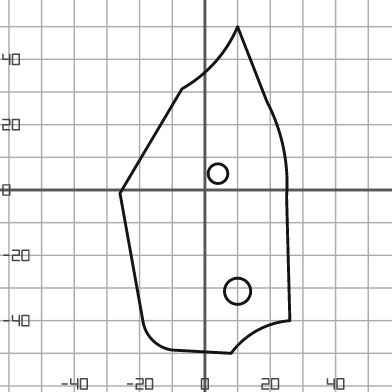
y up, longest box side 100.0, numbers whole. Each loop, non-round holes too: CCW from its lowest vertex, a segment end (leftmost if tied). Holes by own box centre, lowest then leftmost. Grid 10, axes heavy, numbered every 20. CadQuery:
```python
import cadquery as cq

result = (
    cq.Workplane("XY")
    .moveTo(8.0, -50.0)
    .threePointArc((16.0, -43.0), (26.0, -40.0))
    .lineTo(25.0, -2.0)
    .threePointArc((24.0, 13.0), (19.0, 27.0))
    .lineTo(10.0, 50.0)
    .threePointArc((3.0, 39.0), (-7.0, 31.0))
    .lineTo(-26.0, -1.0)
    .lineTo(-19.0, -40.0)
    .threePointArc((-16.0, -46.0), (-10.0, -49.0))
    .close()
    .moveTo(10.0, -31.0)
    .circle(4.0)
    .moveTo(4.0, 5.0)
    .circle(3.0)
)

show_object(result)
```